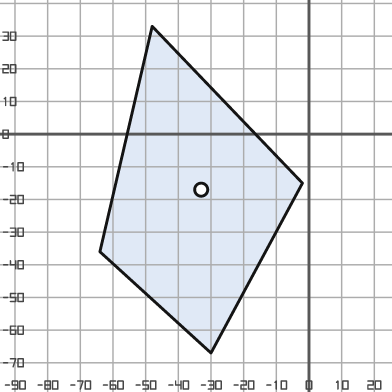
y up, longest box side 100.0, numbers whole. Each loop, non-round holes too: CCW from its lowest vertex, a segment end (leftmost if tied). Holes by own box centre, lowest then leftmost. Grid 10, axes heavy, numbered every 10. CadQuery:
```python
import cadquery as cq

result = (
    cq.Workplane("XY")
    .moveTo(-30.0, -67.0)
    .lineTo(-2.0, -15.0)
    .lineTo(-48.0, 33.0)
    .lineTo(-64.0, -36.0)
    .close()
    .moveTo(-33.0, -17.0)
    .circle(2.0)
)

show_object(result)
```